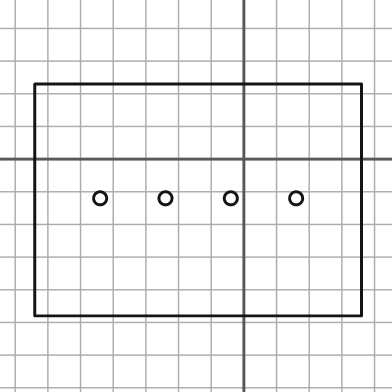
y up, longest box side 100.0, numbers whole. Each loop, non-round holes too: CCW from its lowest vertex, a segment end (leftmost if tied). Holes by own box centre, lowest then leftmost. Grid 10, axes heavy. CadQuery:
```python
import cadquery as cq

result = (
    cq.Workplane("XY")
    .moveTo(-64.0, -48.0)
    .lineTo(36.0, -48.0)
    .lineTo(36.0, 23.0)
    .lineTo(-64.0, 23.0)
    .close()
    .moveTo(-44.0, -12.0)
    .circle(2.0)
    .moveTo(-24.0, -12.0)
    .circle(2.0)
    .moveTo(-4.0, -12.0)
    .circle(2.0)
    .moveTo(16.0, -12.0)
    .circle(2.0)
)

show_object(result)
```